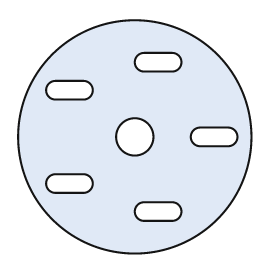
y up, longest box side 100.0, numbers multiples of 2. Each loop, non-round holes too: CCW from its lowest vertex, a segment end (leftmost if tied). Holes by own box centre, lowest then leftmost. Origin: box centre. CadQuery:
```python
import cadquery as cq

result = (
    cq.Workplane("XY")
    .moveTo(0.0, 0.0)
    .circle(50.0)
    .moveTo(4.0, -36.0)
    .lineTo(16.0, -36.0)
    .threePointArc((20.0, -32.0), (16.0, -28.0))
    .lineTo(4.0, -28.0)
    .threePointArc((0.0, -32.0), (4.0, -36.0))
    .close()
    .moveTo(-34.0, -24.0)
    .lineTo(-22.0, -24.0)
    .threePointArc((-18.0, -20.0), (-22.0, -16.0))
    .lineTo(-34.0, -16.0)
    .threePointArc((-38.0, -20.0), (-34.0, -24.0))
    .close()
    .moveTo(0.0, 0.0)
    .circle(8.0)
    .moveTo(28.0, -4.0)
    .lineTo(40.0, -4.0)
    .threePointArc((44.0, 0.0), (40.0, 4.0))
    .lineTo(28.0, 4.0)
    .threePointArc((24.0, 0.0), (28.0, -4.0))
    .close()
    .moveTo(-34.0, 16.0)
    .lineTo(-22.0, 16.0)
    .threePointArc((-18.0, 20.0), (-22.0, 24.0))
    .lineTo(-34.0, 24.0)
    .threePointArc((-38.0, 20.0), (-34.0, 16.0))
    .close()
    .moveTo(4.0, 28.0)
    .lineTo(16.0, 28.0)
    .threePointArc((20.0, 32.0), (16.0, 36.0))
    .lineTo(4.0, 36.0)
    .threePointArc((0.0, 32.0), (4.0, 28.0))
    .close()
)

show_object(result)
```